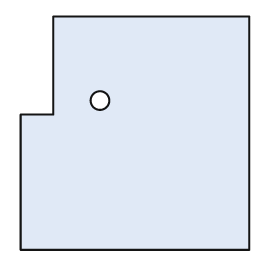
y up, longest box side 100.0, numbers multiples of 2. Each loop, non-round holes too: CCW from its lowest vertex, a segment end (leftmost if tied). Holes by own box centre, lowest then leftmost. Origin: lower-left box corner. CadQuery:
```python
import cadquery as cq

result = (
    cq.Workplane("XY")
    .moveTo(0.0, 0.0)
    .lineTo(98.0, 0.0)
    .lineTo(98.0, 100.0)
    .lineTo(14.0, 100.0)
    .lineTo(14.0, 58.0)
    .lineTo(0.0, 58.0)
    .close()
    .moveTo(34.0, 64.0)
    .circle(4.0)
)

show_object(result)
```